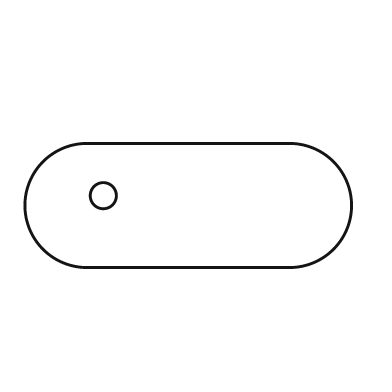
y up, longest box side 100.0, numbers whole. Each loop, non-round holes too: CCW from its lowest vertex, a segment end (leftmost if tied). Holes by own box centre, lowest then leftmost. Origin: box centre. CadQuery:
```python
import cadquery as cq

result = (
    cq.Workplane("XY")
    .moveTo(-31.0, -19.0)
    .lineTo(31.0, -19.0)
    .threePointArc((50.0, 0.0), (31.0, 19.0))
    .lineTo(-31.0, 19.0)
    .threePointArc((-50.0, 0.0), (-31.0, -19.0))
    .close()
    .moveTo(-26.0, 3.0)
    .circle(4.0)
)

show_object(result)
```